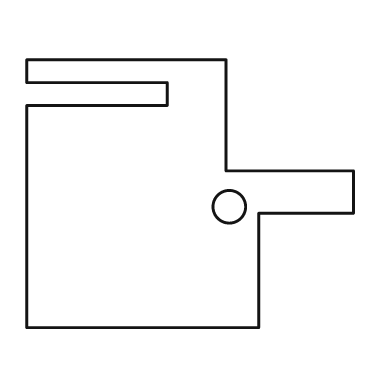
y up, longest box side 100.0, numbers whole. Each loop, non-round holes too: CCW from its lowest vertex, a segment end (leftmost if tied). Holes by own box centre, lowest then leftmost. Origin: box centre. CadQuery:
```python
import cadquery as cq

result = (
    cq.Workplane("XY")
    .moveTo(-50.0, -41.0)
    .lineTo(21.0, -41.0)
    .lineTo(21.0, -6.0)
    .lineTo(50.0, -6.0)
    .lineTo(50.0, 7.0)
    .lineTo(11.0, 7.0)
    .lineTo(11.0, 41.0)
    .lineTo(-50.0, 41.0)
    .lineTo(-50.0, 34.0)
    .lineTo(-7.0, 34.0)
    .lineTo(-7.0, 27.0)
    .lineTo(-50.0, 27.0)
    .close()
    .moveTo(12.0, -4.0)
    .circle(5.0)
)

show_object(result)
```